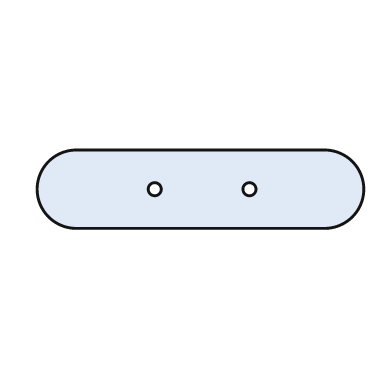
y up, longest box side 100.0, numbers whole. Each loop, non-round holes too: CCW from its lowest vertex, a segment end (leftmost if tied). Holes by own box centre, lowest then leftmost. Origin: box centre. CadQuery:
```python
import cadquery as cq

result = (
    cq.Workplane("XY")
    .moveTo(-38.0, -12.0)
    .lineTo(38.0, -12.0)
    .threePointArc((50.0, 0.0), (38.0, 12.0))
    .lineTo(-38.0, 12.0)
    .threePointArc((-50.0, 0.0), (-38.0, -12.0))
    .close()
    .moveTo(-14.0, 0.0)
    .circle(2.0)
    .moveTo(15.0, 0.0)
    .circle(2.0)
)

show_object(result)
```